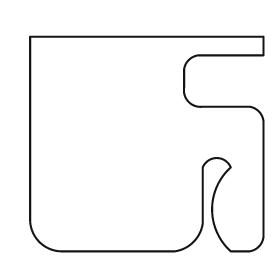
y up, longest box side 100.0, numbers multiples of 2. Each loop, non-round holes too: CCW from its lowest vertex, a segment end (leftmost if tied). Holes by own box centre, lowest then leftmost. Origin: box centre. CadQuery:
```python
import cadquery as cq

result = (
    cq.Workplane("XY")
    .moveTo(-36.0, -46.0)
    .lineTo(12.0, -46.0)
    .threePointArc((20.0, -42.0), (24.0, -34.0))
    .lineTo(24.0, -10.0)
    .threePointArc((30.0, -6.0), (36.0, -10.0))
    .threePointArc((28.0, -28.0), (36.0, -46.0))
    .lineTo(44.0, -46.0)
    .threePointArc((48.0, -44.0), (50.0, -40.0))
    .lineTo(50.0, 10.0)
    .threePointArc((48.0, 14.0), (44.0, 16.0))
    .lineTo(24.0, 16.0)
    .threePointArc((18.0, 18.0), (16.0, 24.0))
    .lineTo(16.0, 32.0)
    .threePointArc((18.0, 36.0), (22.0, 38.0))
    .lineTo(50.0, 38.0)
    .lineTo(50.0, 46.0)
    .lineTo(-50.0, 46.0)
    .lineTo(-50.0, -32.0)
    .threePointArc((-46.0, -42.0), (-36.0, -46.0))
    .close()
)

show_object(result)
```